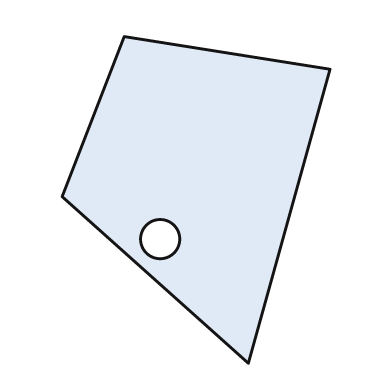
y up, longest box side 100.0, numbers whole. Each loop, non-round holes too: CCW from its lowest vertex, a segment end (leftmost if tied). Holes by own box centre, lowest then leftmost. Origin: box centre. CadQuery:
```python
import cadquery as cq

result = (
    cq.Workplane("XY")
    .moveTo(16.0, -50.0)
    .lineTo(41.0, 40.0)
    .lineTo(-22.0, 50.0)
    .lineTo(-41.0, 1.0)
    .close()
    .moveTo(-11.0, -12.0)
    .circle(6.0)
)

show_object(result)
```